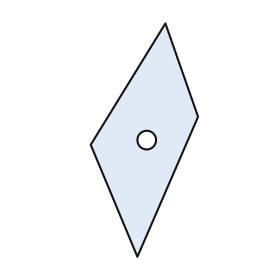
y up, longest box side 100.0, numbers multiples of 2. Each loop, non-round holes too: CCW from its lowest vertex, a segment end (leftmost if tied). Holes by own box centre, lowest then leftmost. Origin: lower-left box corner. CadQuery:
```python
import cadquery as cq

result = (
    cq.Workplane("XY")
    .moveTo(20.0, 0.0)
    .lineTo(46.0, 60.0)
    .lineTo(32.0, 100.0)
    .lineTo(0.0, 48.0)
    .close()
    .moveTo(24.0, 50.0)
    .circle(4.0)
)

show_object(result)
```